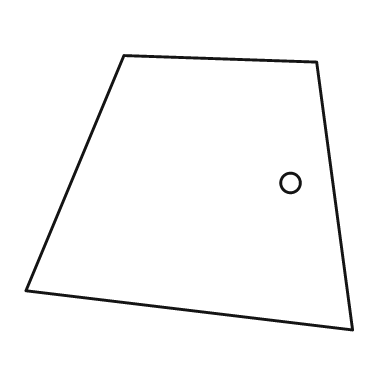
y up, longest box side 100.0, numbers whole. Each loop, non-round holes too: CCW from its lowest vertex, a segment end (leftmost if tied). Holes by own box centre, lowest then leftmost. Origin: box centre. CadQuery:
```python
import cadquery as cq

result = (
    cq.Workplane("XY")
    .moveTo(50.0, -42.0)
    .lineTo(39.0, 40.0)
    .lineTo(-20.0, 42.0)
    .lineTo(-50.0, -30.0)
    .close()
    .moveTo(31.0, 3.0)
    .circle(3.0)
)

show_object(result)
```